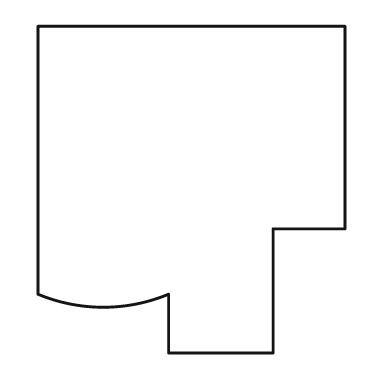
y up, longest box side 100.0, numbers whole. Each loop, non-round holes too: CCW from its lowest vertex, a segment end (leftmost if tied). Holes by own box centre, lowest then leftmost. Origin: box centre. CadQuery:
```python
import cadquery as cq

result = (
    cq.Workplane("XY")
    .moveTo(-7.0, -50.0)
    .lineTo(25.0, -50.0)
    .lineTo(25.0, -12.0)
    .lineTo(47.0, -12.0)
    .lineTo(47.0, 50.0)
    .lineTo(-47.0, 50.0)
    .lineTo(-47.0, -32.0)
    .threePointArc((-27.0, -36.0), (-7.0, -32.0))
    .close()
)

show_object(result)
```